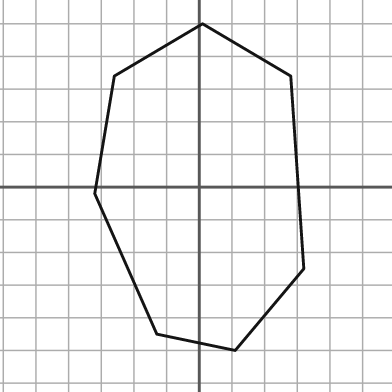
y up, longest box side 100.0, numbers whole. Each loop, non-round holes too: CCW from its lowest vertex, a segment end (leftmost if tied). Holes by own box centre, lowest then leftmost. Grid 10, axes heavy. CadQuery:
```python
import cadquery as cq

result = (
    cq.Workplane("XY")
    .moveTo(11.0, -50.0)
    .lineTo(32.0, -25.0)
    .lineTo(28.0, 34.0)
    .lineTo(1.0, 50.0)
    .lineTo(-26.0, 34.0)
    .lineTo(-32.0, -2.0)
    .lineTo(-13.0, -45.0)
    .close()
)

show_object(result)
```